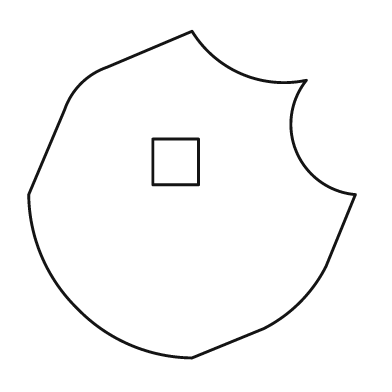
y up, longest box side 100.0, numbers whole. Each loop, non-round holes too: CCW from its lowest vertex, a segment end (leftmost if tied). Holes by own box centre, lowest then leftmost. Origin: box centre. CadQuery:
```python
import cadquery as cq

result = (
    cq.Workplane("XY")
    .moveTo(0.0, -50.0)
    .lineTo(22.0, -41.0)
    .threePointArc((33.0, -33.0), (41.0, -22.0))
    .lineTo(50.0, 0.0)
    .threePointArc((32.0, 13.0), (35.0, 35.0))
    .threePointArc((15.0, 37.0), (0.0, 50.0))
    .lineTo(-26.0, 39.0)
    .threePointArc((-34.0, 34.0), (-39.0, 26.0))
    .lineTo(-50.0, 0.0)
    .threePointArc((-46.0, -19.0), (-35.0, -35.0))
    .threePointArc((-19.0, -46.0), (0.0, -50.0))
    .close()
    .moveTo(-12.0, 3.0)
    .lineTo(2.0, 3.0)
    .lineTo(2.0, 17.0)
    .lineTo(-12.0, 17.0)
    .close()
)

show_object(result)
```